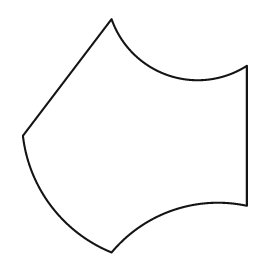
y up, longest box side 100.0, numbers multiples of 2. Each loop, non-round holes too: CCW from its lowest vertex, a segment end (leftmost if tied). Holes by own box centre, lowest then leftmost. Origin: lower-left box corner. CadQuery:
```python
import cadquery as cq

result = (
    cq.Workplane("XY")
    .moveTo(38.0, 0.0)
    .threePointArc((64.0, 18.0), (96.0, 20.0))
    .lineTo(96.0, 80.0)
    .threePointArc((62.0, 76.0), (38.0, 100.0))
    .lineTo(0.0, 50.0)
    .threePointArc((12.0, 20.0), (38.0, 0.0))
    .close()
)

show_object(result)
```